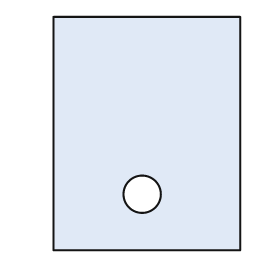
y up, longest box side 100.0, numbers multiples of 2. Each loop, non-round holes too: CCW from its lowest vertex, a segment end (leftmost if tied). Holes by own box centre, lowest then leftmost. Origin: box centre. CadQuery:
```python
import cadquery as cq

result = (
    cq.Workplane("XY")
    .moveTo(-40.0, -50.0)
    .lineTo(40.0, -50.0)
    .lineTo(40.0, 50.0)
    .lineTo(-40.0, 50.0)
    .close()
    .moveTo(-2.0, -26.0)
    .circle(8.0)
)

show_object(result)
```